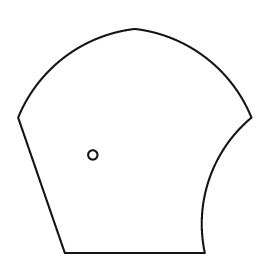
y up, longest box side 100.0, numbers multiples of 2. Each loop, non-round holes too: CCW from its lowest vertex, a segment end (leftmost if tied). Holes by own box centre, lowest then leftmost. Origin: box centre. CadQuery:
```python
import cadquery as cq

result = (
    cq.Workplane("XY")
    .moveTo(-30.0, -48.0)
    .lineTo(30.0, -48.0)
    .threePointArc((32.0, -16.0), (50.0, 10.0))
    .threePointArc((30.0, 36.0), (0.0, 48.0))
    .threePointArc((-30.0, 36.0), (-50.0, 10.0))
    .close()
    .moveTo(-18.0, -6.0)
    .circle(2.0)
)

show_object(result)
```